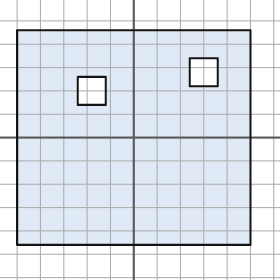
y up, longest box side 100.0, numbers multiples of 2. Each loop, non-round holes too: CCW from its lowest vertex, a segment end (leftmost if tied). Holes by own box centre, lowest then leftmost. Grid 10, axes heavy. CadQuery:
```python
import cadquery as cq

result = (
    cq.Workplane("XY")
    .moveTo(-50.0, -46.0)
    .lineTo(50.0, -46.0)
    .lineTo(50.0, 46.0)
    .lineTo(-50.0, 46.0)
    .close()
    .moveTo(-24.0, 14.0)
    .lineTo(-12.0, 14.0)
    .lineTo(-12.0, 26.0)
    .lineTo(-24.0, 26.0)
    .close()
    .moveTo(24.0, 22.0)
    .lineTo(36.0, 22.0)
    .lineTo(36.0, 34.0)
    .lineTo(24.0, 34.0)
    .close()
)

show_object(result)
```